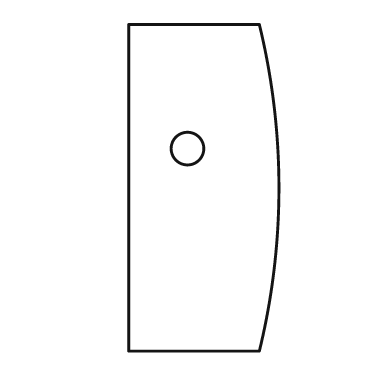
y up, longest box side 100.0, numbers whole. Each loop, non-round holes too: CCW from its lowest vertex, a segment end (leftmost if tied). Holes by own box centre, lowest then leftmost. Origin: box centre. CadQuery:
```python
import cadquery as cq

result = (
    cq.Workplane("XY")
    .moveTo(-23.0, -50.0)
    .lineTo(17.0, -50.0)
    .threePointArc((23.0, 0.0), (17.0, 50.0))
    .lineTo(-23.0, 50.0)
    .close()
    .moveTo(-5.0, 12.0)
    .circle(5.0)
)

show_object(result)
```